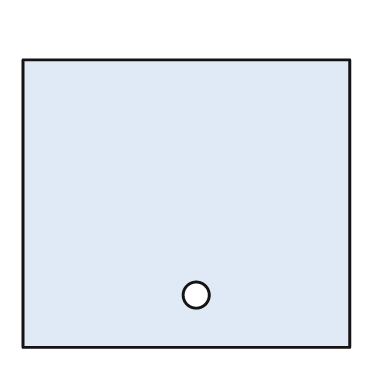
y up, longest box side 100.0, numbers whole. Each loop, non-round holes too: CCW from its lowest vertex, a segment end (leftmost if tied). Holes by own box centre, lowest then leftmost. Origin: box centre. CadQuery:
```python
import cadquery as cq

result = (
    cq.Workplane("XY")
    .moveTo(-50.0, -44.0)
    .lineTo(50.0, -44.0)
    .lineTo(50.0, 44.0)
    .lineTo(-50.0, 44.0)
    .close()
    .moveTo(3.0, -28.0)
    .circle(4.0)
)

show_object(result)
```